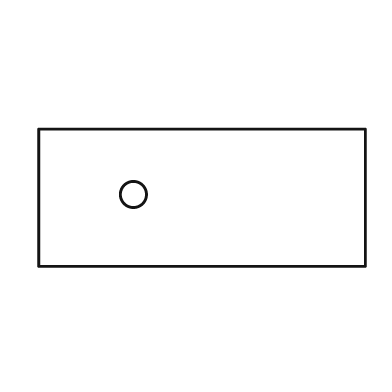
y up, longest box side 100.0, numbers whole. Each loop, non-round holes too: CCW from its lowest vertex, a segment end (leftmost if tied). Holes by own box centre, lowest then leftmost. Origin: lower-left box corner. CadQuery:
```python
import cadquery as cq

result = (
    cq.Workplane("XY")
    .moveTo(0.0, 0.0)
    .lineTo(100.0, 0.0)
    .lineTo(100.0, 42.0)
    .lineTo(0.0, 42.0)
    .close()
    .moveTo(29.0, 22.0)
    .circle(4.0)
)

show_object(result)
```